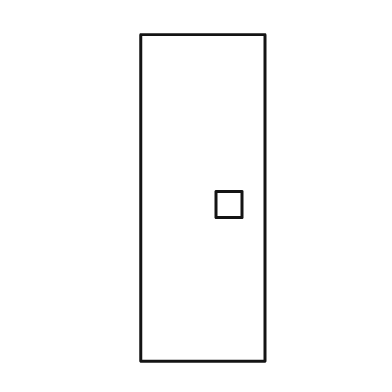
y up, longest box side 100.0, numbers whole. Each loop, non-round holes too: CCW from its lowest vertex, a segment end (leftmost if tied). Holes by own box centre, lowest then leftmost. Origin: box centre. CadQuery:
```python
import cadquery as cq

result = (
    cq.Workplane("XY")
    .moveTo(-19.0, -50.0)
    .lineTo(19.0, -50.0)
    .lineTo(19.0, 50.0)
    .lineTo(-19.0, 50.0)
    .close()
    .moveTo(4.0, -6.0)
    .lineTo(12.0, -6.0)
    .lineTo(12.0, 2.0)
    .lineTo(4.0, 2.0)
    .close()
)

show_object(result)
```